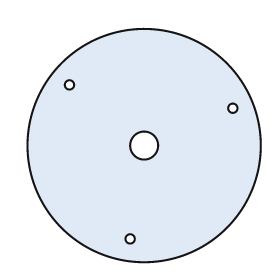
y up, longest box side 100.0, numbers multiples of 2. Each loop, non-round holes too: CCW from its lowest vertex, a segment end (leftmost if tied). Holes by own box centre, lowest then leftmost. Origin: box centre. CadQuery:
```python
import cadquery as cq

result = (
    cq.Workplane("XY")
    .moveTo(0.0, 0.0)
    .circle(50.0)
    .moveTo(-6.0, -40.0)
    .circle(2.0)
    .moveTo(0.0, 0.0)
    .circle(6.0)
    .moveTo(38.0, 16.0)
    .circle(2.0)
    .moveTo(-32.0, 26.0)
    .circle(2.0)
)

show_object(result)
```